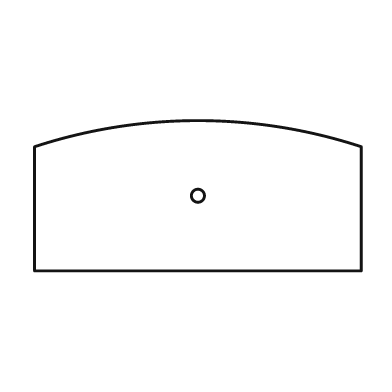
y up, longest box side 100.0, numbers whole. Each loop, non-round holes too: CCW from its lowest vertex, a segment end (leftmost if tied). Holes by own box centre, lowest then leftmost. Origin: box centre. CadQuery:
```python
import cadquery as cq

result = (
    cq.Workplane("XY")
    .moveTo(-50.0, -23.0)
    .lineTo(50.0, -23.0)
    .lineTo(50.0, 15.0)
    .threePointArc((0.0, 23.0), (-50.0, 15.0))
    .close()
    .moveTo(0.0, 0.0)
    .circle(2.0)
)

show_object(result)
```